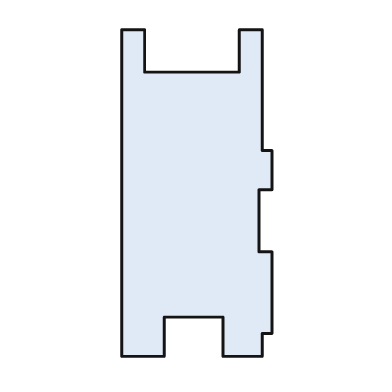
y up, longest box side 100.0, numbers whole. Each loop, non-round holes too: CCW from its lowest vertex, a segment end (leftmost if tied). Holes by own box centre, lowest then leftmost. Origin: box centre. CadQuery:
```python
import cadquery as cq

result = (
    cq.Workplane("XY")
    .moveTo(-23.0, -50.0)
    .lineTo(-10.0, -50.0)
    .lineTo(-10.0, -38.0)
    .lineTo(8.0, -38.0)
    .lineTo(8.0, -50.0)
    .lineTo(20.0, -50.0)
    .lineTo(20.0, -43.0)
    .lineTo(23.0, -43.0)
    .lineTo(23.0, -18.0)
    .lineTo(19.0, -18.0)
    .lineTo(19.0, 1.0)
    .lineTo(23.0, 1.0)
    .lineTo(23.0, 13.0)
    .lineTo(20.0, 13.0)
    .lineTo(20.0, 50.0)
    .lineTo(13.0, 50.0)
    .lineTo(13.0, 37.0)
    .lineTo(-16.0, 37.0)
    .lineTo(-16.0, 50.0)
    .lineTo(-23.0, 50.0)
    .close()
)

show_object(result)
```